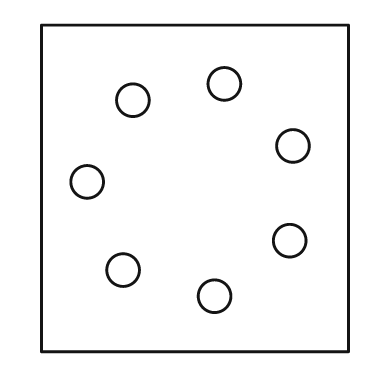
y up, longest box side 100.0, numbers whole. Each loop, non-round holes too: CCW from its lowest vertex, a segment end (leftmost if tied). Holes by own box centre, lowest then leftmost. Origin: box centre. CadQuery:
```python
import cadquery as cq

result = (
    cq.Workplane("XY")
    .moveTo(-47.0, -50.0)
    .lineTo(47.0, -50.0)
    .lineTo(47.0, 50.0)
    .lineTo(-47.0, 50.0)
    .close()
    .moveTo(6.0, -33.0)
    .circle(5.0)
    .moveTo(-22.0, -25.0)
    .circle(5.0)
    .moveTo(29.0, -16.0)
    .circle(5.0)
    .moveTo(-33.0, 2.0)
    .circle(5.0)
    .moveTo(30.0, 13.0)
    .circle(5.0)
    .moveTo(-19.0, 27.0)
    .circle(5.0)
    .moveTo(9.0, 32.0)
    .circle(5.0)
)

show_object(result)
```